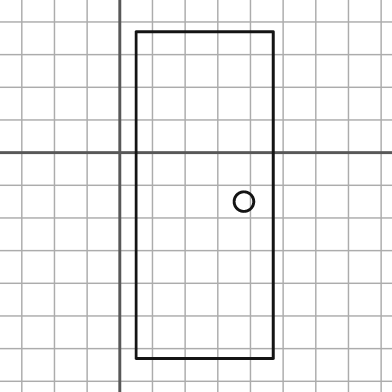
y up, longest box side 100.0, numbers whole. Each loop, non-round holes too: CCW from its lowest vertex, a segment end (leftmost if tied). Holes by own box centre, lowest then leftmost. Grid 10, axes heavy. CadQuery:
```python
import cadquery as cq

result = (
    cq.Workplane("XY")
    .moveTo(5.0, -63.0)
    .lineTo(47.0, -63.0)
    .lineTo(47.0, 37.0)
    .lineTo(5.0, 37.0)
    .close()
    .moveTo(38.0, -15.0)
    .circle(3.0)
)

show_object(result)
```